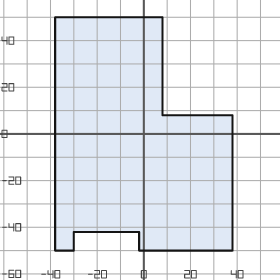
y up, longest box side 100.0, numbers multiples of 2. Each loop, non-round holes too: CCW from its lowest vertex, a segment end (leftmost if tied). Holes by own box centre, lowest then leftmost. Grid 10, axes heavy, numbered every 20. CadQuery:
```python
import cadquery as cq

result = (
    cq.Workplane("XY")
    .moveTo(-38.0, -50.0)
    .lineTo(-30.0, -50.0)
    .lineTo(-30.0, -42.0)
    .lineTo(-2.0, -42.0)
    .lineTo(-2.0, -50.0)
    .lineTo(38.0, -50.0)
    .lineTo(38.0, 8.0)
    .lineTo(8.0, 8.0)
    .lineTo(8.0, 50.0)
    .lineTo(-38.0, 50.0)
    .close()
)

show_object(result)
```